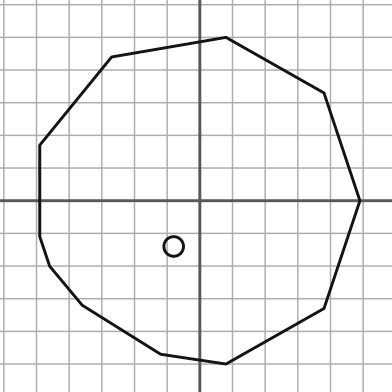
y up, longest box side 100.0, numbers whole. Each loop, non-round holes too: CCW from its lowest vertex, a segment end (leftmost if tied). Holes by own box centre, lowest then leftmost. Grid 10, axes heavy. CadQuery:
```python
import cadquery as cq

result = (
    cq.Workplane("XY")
    .moveTo(8.0, -50.0)
    .lineTo(38.0, -33.0)
    .lineTo(49.0, 0.0)
    .lineTo(38.0, 33.0)
    .lineTo(8.0, 50.0)
    .lineTo(-27.0, 44.0)
    .lineTo(-49.0, 17.0)
    .lineTo(-49.0, -11.0)
    .lineTo(-46.0, -20.0)
    .lineTo(-36.0, -32.0)
    .lineTo(-12.0, -47.0)
    .close()
    .moveTo(-8.0, -14.0)
    .circle(3.0)
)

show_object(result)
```